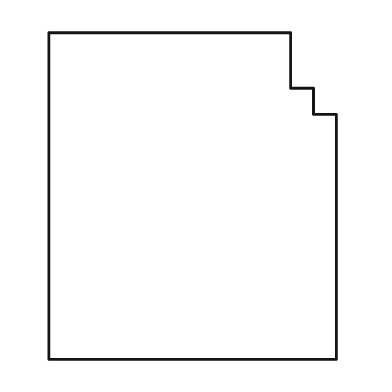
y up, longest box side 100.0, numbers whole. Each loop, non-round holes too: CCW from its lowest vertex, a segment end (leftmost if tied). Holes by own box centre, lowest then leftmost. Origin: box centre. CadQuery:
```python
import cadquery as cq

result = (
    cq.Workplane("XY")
    .moveTo(-44.0, -50.0)
    .lineTo(44.0, -50.0)
    .lineTo(44.0, 25.0)
    .lineTo(37.0, 25.0)
    .lineTo(37.0, 33.0)
    .lineTo(30.0, 33.0)
    .lineTo(30.0, 50.0)
    .lineTo(-44.0, 50.0)
    .close()
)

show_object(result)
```